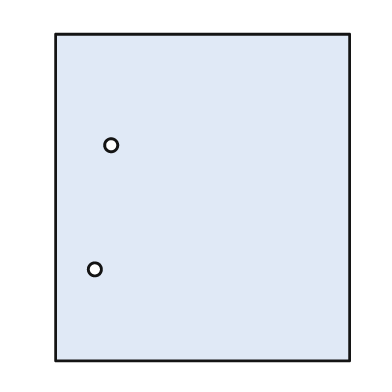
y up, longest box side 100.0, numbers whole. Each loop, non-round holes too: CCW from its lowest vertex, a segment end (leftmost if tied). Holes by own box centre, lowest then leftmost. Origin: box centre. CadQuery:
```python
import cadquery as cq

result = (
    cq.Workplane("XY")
    .moveTo(-45.0, -50.0)
    .lineTo(45.0, -50.0)
    .lineTo(45.0, 50.0)
    .lineTo(-45.0, 50.0)
    .close()
    .moveTo(-33.0, -22.0)
    .circle(2.0)
    .moveTo(-28.0, 16.0)
    .circle(2.0)
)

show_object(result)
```